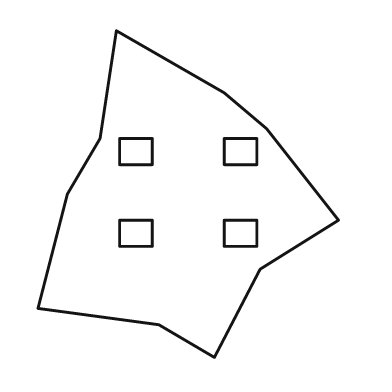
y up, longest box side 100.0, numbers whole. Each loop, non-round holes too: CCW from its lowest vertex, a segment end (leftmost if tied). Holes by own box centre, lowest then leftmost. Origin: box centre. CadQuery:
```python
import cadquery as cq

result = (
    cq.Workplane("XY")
    .moveTo(8.0, -50.0)
    .lineTo(22.0, -23.0)
    .lineTo(46.0, -8.0)
    .lineTo(24.0, 20.0)
    .lineTo(11.0, 31.0)
    .lineTo(-22.0, 50.0)
    .lineTo(-27.0, 17.0)
    .lineTo(-37.0, 0.0)
    .lineTo(-46.0, -35.0)
    .lineTo(-9.0, -40.0)
    .close()
    .moveTo(-21.0, -16.0)
    .lineTo(-11.0, -16.0)
    .lineTo(-11.0, -8.0)
    .lineTo(-21.0, -8.0)
    .close()
    .moveTo(11.0, -16.0)
    .lineTo(21.0, -16.0)
    .lineTo(21.0, -8.0)
    .lineTo(11.0, -8.0)
    .close()
    .moveTo(-21.0, 9.0)
    .lineTo(-11.0, 9.0)
    .lineTo(-11.0, 17.0)
    .lineTo(-21.0, 17.0)
    .close()
    .moveTo(11.0, 9.0)
    .lineTo(21.0, 9.0)
    .lineTo(21.0, 17.0)
    .lineTo(11.0, 17.0)
    .close()
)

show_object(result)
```